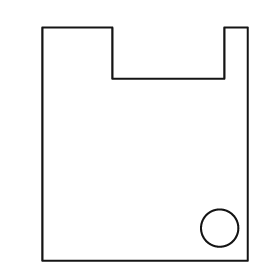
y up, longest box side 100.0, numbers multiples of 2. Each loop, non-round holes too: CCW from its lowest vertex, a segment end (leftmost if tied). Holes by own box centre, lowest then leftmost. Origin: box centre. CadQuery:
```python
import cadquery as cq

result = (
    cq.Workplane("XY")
    .moveTo(-44.0, -50.0)
    .lineTo(44.0, -50.0)
    .lineTo(44.0, 50.0)
    .lineTo(34.0, 50.0)
    .lineTo(34.0, 28.0)
    .lineTo(-14.0, 28.0)
    .lineTo(-14.0, 50.0)
    .lineTo(-44.0, 50.0)
    .close()
    .moveTo(32.0, -36.0)
    .circle(8.0)
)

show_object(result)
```